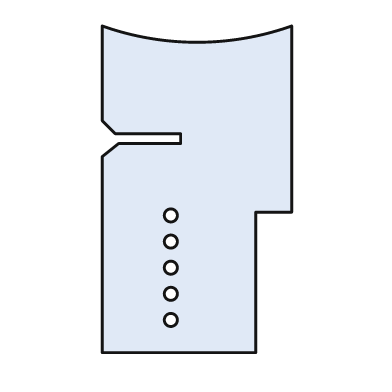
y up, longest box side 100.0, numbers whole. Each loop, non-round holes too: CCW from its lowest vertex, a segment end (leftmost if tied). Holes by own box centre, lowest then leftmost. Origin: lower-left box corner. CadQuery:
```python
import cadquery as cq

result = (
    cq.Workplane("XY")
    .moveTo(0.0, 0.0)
    .lineTo(47.0, 0.0)
    .lineTo(47.0, 43.0)
    .lineTo(58.0, 43.0)
    .lineTo(58.0, 100.0)
    .threePointArc((29.0, 95.0), (0.0, 100.0))
    .lineTo(0.0, 71.0)
    .lineTo(4.0, 67.0)
    .lineTo(24.0, 67.0)
    .lineTo(24.0, 64.0)
    .lineTo(5.0, 64.0)
    .lineTo(0.0, 60.0)
    .close()
    .moveTo(21.0, 10.0)
    .circle(2.0)
    .moveTo(21.0, 18.0)
    .circle(2.0)
    .moveTo(21.0, 26.0)
    .circle(2.0)
    .moveTo(21.0, 34.0)
    .circle(2.0)
    .moveTo(21.0, 42.0)
    .circle(2.0)
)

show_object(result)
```